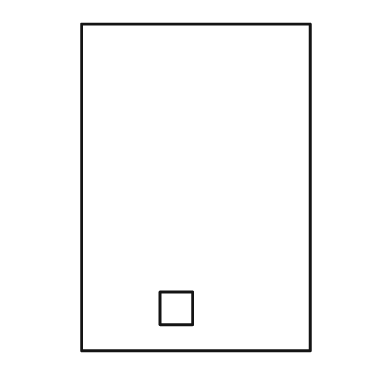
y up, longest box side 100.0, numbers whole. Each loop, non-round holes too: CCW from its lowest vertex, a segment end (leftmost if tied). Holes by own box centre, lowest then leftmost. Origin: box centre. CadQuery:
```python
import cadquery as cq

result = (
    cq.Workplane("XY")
    .moveTo(-35.0, -50.0)
    .lineTo(35.0, -50.0)
    .lineTo(35.0, 50.0)
    .lineTo(-35.0, 50.0)
    .close()
    .moveTo(-11.0, -42.0)
    .lineTo(-1.0, -42.0)
    .lineTo(-1.0, -32.0)
    .lineTo(-11.0, -32.0)
    .close()
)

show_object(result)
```